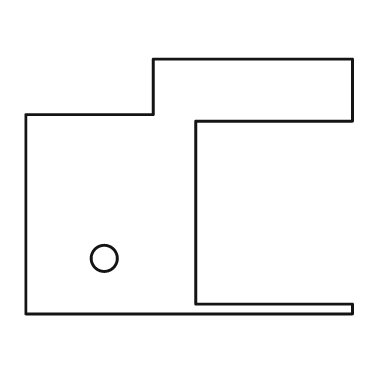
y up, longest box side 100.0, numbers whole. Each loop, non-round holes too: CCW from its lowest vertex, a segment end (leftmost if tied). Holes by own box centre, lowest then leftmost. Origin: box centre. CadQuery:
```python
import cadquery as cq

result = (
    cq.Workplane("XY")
    .moveTo(-50.0, -39.0)
    .lineTo(50.0, -39.0)
    .lineTo(50.0, -36.0)
    .lineTo(2.0, -36.0)
    .lineTo(2.0, 20.0)
    .lineTo(50.0, 20.0)
    .lineTo(50.0, 39.0)
    .lineTo(-11.0, 39.0)
    .lineTo(-11.0, 22.0)
    .lineTo(-50.0, 22.0)
    .close()
    .moveTo(-26.0, -22.0)
    .circle(4.0)
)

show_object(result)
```